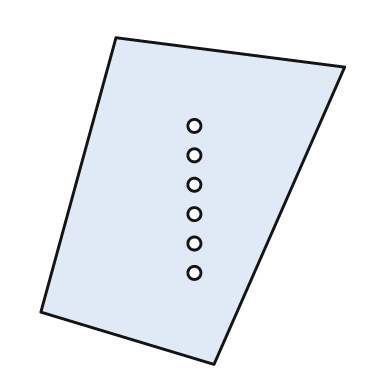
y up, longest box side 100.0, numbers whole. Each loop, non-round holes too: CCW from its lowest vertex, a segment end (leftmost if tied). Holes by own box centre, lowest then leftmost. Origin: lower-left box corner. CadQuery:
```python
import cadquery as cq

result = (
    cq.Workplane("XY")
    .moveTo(53.0, 0.0)
    .lineTo(93.0, 91.0)
    .lineTo(23.0, 100.0)
    .lineTo(0.0, 16.0)
    .close()
    .moveTo(47.0, 28.0)
    .circle(2.0)
    .moveTo(47.0, 37.0)
    .circle(2.0)
    .moveTo(47.0, 46.0)
    .circle(2.0)
    .moveTo(47.0, 55.0)
    .circle(2.0)
    .moveTo(47.0, 64.0)
    .circle(2.0)
    .moveTo(47.0, 73.0)
    .circle(2.0)
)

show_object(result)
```